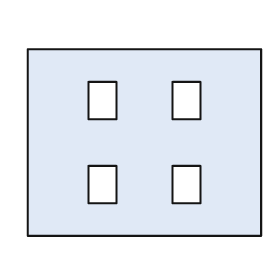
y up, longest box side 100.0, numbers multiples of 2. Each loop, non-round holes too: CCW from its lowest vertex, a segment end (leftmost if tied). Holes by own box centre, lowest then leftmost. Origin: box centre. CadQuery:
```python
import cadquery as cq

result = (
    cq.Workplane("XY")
    .moveTo(-50.0, -40.0)
    .lineTo(50.0, -40.0)
    .lineTo(50.0, 40.0)
    .lineTo(-50.0, 40.0)
    .close()
    .moveTo(-24.0, -26.0)
    .lineTo(-12.0, -26.0)
    .lineTo(-12.0, -10.0)
    .lineTo(-24.0, -10.0)
    .close()
    .moveTo(12.0, -26.0)
    .lineTo(24.0, -26.0)
    .lineTo(24.0, -10.0)
    .lineTo(12.0, -10.0)
    .close()
    .moveTo(-24.0, 10.0)
    .lineTo(-12.0, 10.0)
    .lineTo(-12.0, 26.0)
    .lineTo(-24.0, 26.0)
    .close()
    .moveTo(12.0, 10.0)
    .lineTo(24.0, 10.0)
    .lineTo(24.0, 26.0)
    .lineTo(12.0, 26.0)
    .close()
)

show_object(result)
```